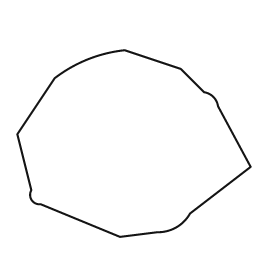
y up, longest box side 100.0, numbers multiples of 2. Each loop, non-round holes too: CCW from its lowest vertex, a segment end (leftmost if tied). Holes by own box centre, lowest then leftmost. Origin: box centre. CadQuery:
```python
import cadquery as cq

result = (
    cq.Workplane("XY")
    .moveTo(-6.0, -40.0)
    .lineTo(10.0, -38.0)
    .threePointArc((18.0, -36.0), (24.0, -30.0))
    .lineTo(50.0, -10.0)
    .lineTo(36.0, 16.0)
    .threePointArc((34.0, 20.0), (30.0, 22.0))
    .lineTo(20.0, 32.0)
    .lineTo(-4.0, 40.0)
    .threePointArc((-20.0, 36.0), (-34.0, 28.0))
    .lineTo(-50.0, 4.0)
    .lineTo(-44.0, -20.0)
    .threePointArc((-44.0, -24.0), (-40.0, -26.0))
    .close()
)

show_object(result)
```